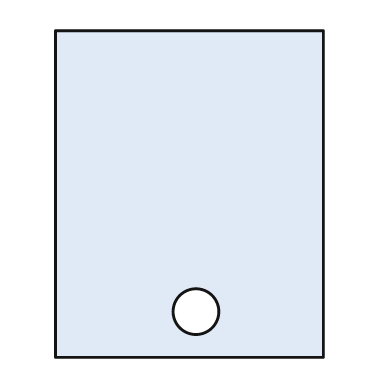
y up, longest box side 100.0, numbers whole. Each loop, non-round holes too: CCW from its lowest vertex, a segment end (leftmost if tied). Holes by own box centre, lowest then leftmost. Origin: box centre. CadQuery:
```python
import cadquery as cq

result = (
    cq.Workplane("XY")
    .moveTo(-41.0, -50.0)
    .lineTo(41.0, -50.0)
    .lineTo(41.0, 50.0)
    .lineTo(-41.0, 50.0)
    .close()
    .moveTo(2.0, -36.0)
    .circle(7.0)
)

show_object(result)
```